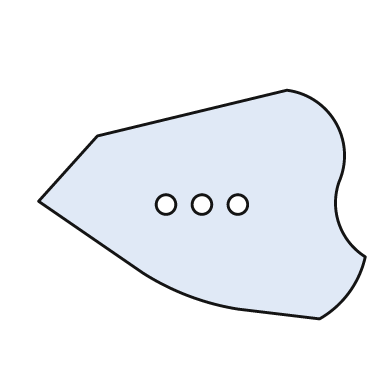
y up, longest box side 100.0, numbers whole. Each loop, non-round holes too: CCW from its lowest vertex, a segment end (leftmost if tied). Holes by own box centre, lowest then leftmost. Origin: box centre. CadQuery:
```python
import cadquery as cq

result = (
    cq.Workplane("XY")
    .moveTo(36.0, -35.0)
    .threePointArc((45.0, -27.0), (50.0, -16.0))
    .threePointArc((42.0, -6.0), (42.0, 7.0))
    .threePointArc((41.0, 25.0), (26.0, 35.0))
    .lineTo(-32.0, 21.0)
    .lineTo(-50.0, 1.0)
    .lineTo(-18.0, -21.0)
    .threePointArc((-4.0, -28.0), (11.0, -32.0))
    .close()
    .moveTo(-11.0, 0.0)
    .circle(3.0)
    .moveTo(0.0, 0.0)
    .circle(3.0)
    .moveTo(11.0, 0.0)
    .circle(3.0)
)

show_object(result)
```